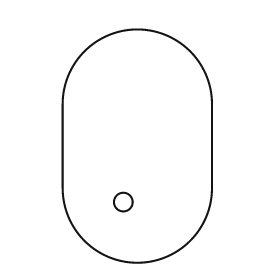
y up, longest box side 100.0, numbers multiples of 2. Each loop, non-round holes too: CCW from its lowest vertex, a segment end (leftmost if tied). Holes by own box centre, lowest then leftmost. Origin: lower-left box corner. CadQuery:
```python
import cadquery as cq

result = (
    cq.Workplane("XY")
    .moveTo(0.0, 32.0)
    .threePointArc((32.0, 0.0), (64.0, 32.0))
    .lineTo(64.0, 68.0)
    .threePointArc((32.0, 100.0), (0.0, 68.0))
    .close()
    .moveTo(26.0, 26.0)
    .circle(4.0)
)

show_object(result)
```